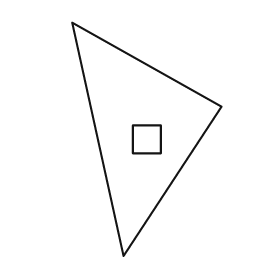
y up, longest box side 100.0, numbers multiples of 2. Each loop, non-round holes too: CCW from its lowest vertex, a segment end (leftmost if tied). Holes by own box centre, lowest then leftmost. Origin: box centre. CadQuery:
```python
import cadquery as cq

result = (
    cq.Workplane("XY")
    .moveTo(-10.0, -50.0)
    .lineTo(32.0, 14.0)
    .lineTo(-32.0, 50.0)
    .close()
    .moveTo(-6.0, -6.0)
    .lineTo(6.0, -6.0)
    .lineTo(6.0, 6.0)
    .lineTo(-6.0, 6.0)
    .close()
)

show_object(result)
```